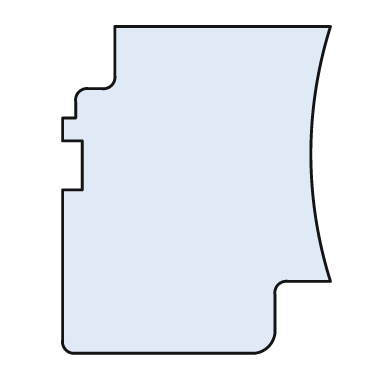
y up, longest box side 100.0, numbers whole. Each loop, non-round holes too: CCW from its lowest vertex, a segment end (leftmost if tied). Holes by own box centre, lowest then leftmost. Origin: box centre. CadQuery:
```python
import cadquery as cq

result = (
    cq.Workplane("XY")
    .moveTo(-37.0, -50.0)
    .lineTo(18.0, -50.0)
    .threePointArc((22.0, -48.0), (24.0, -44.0))
    .lineTo(24.0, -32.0)
    .threePointArc((25.0, -29.0), (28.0, -28.0))
    .lineTo(41.0, -28.0)
    .threePointArc((35.0, 11.0), (41.0, 50.0))
    .lineTo(-25.0, 50.0)
    .lineTo(-25.0, 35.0)
    .threePointArc((-26.0, 32.0), (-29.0, 31.0))
    .lineTo(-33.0, 31.0)
    .threePointArc((-36.0, 30.0), (-37.0, 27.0))
    .lineTo(-37.0, 22.0)
    .lineTo(-41.0, 22.0)
    .lineTo(-41.0, 15.0)
    .lineTo(-35.0, 15.0)
    .lineTo(-35.0, 0.0)
    .lineTo(-41.0, 0.0)
    .lineTo(-41.0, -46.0)
    .threePointArc((-40.0, -49.0), (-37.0, -50.0))
    .close()
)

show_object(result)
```